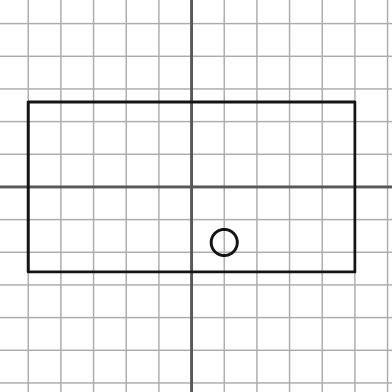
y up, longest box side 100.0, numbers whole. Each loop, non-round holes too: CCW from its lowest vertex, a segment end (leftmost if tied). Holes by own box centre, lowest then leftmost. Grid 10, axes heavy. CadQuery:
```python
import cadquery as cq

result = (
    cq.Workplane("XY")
    .moveTo(-50.0, -26.0)
    .lineTo(50.0, -26.0)
    .lineTo(50.0, 26.0)
    .lineTo(-50.0, 26.0)
    .close()
    .moveTo(10.0, -17.0)
    .circle(4.0)
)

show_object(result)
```